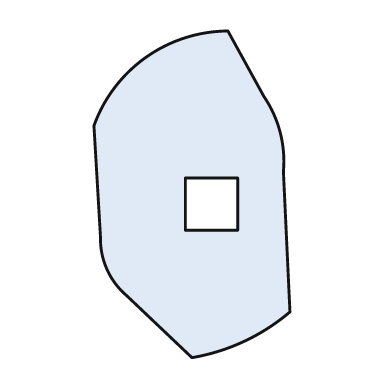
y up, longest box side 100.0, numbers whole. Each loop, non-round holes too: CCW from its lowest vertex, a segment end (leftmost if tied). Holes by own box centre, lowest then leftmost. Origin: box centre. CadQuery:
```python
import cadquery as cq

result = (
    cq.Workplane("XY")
    .moveTo(0.0, -50.0)
    .threePointArc((16.0, -45.0), (30.0, -36.0))
    .lineTo(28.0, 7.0)
    .threePointArc((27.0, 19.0), (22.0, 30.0))
    .lineTo(11.0, 50.0)
    .threePointArc((-14.0, 42.0), (-30.0, 21.0))
    .lineTo(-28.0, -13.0)
    .threePointArc((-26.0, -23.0), (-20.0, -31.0))
    .close()
    .moveTo(-2.0, -11.0)
    .lineTo(14.0, -11.0)
    .lineTo(14.0, 5.0)
    .lineTo(-2.0, 5.0)
    .close()
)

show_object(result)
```